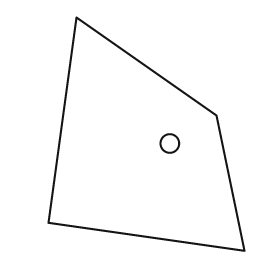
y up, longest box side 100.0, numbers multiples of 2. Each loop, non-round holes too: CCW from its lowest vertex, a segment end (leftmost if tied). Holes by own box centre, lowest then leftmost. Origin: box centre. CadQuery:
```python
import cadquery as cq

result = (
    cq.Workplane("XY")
    .moveTo(42.0, -50.0)
    .lineTo(30.0, 8.0)
    .lineTo(-30.0, 50.0)
    .lineTo(-42.0, -38.0)
    .close()
    .moveTo(10.0, -4.0)
    .circle(4.0)
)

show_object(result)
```